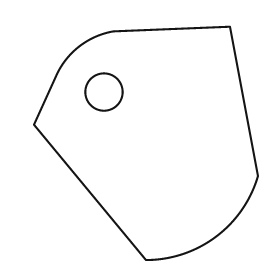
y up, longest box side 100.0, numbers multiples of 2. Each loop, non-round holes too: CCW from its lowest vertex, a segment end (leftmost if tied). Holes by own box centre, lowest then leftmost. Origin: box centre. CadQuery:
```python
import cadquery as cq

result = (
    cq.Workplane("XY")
    .moveTo(0.0, -50.0)
    .threePointArc((30.0, -40.0), (48.0, -14.0))
    .lineTo(36.0, 50.0)
    .lineTo(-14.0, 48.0)
    .threePointArc((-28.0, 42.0), (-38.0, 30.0))
    .lineTo(-48.0, 8.0)
    .close()
    .moveTo(-18.0, 22.0)
    .circle(8.0)
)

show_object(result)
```